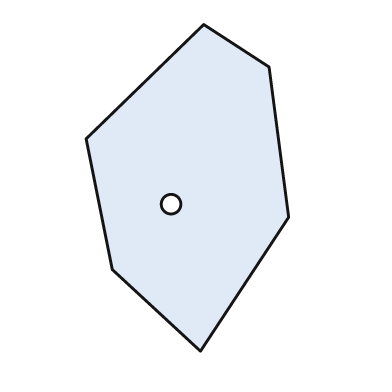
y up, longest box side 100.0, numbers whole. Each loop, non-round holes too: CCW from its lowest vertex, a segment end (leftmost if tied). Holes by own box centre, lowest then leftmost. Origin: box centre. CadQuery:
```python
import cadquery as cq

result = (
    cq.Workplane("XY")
    .moveTo(4.0, -50.0)
    .lineTo(31.0, -9.0)
    .lineTo(25.0, 37.0)
    .lineTo(5.0, 50.0)
    .lineTo(-31.0, 15.0)
    .lineTo(-23.0, -25.0)
    .close()
    .moveTo(-5.0, -5.0)
    .circle(3.0)
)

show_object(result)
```